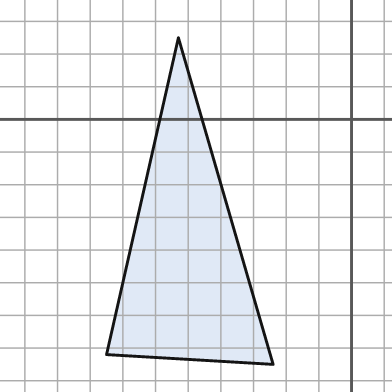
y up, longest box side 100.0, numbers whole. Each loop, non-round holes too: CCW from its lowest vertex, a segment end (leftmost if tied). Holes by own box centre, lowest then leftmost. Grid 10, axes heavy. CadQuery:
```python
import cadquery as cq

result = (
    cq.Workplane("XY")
    .moveTo(-24.0, -75.0)
    .lineTo(-53.0, 25.0)
    .lineTo(-75.0, -72.0)
    .close()
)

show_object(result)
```